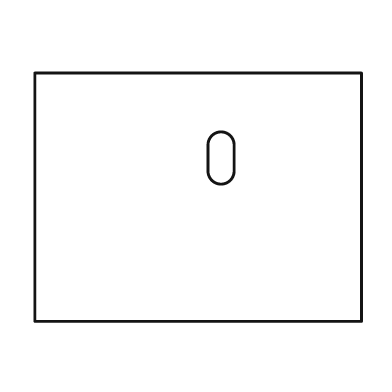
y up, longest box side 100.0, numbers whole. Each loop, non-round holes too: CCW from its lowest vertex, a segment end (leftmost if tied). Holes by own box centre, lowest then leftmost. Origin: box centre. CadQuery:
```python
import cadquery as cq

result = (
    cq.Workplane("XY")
    .moveTo(-50.0, -38.0)
    .lineTo(50.0, -38.0)
    .lineTo(50.0, 38.0)
    .lineTo(-50.0, 38.0)
    .close()
    .moveTo(3.0, 8.0)
    .threePointArc((7.0, 4.0), (11.0, 8.0))
    .lineTo(11.0, 16.0)
    .threePointArc((7.0, 20.0), (3.0, 16.0))
    .close()
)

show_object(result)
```